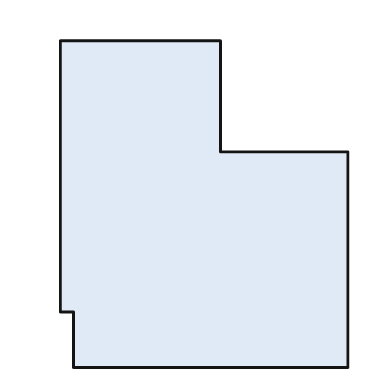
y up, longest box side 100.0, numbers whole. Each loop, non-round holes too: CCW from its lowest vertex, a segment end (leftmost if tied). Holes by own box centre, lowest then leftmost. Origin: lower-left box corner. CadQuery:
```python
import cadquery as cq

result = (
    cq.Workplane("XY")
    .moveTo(4.0, 0.0)
    .lineTo(88.0, 0.0)
    .lineTo(88.0, 66.0)
    .lineTo(49.0, 66.0)
    .lineTo(49.0, 100.0)
    .lineTo(0.0, 100.0)
    .lineTo(0.0, 17.0)
    .lineTo(4.0, 17.0)
    .close()
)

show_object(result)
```